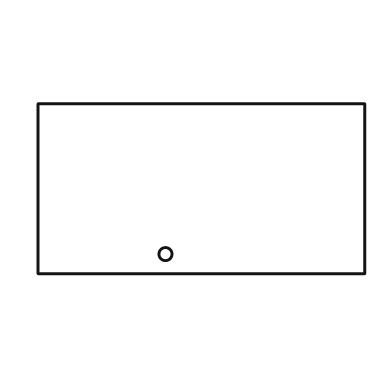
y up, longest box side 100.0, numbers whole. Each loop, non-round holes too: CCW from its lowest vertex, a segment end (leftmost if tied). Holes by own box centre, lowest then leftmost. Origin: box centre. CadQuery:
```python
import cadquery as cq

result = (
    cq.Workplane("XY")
    .moveTo(-50.0, -26.0)
    .lineTo(50.0, -26.0)
    .lineTo(50.0, 26.0)
    .lineTo(-50.0, 26.0)
    .close()
    .moveTo(-11.0, -20.0)
    .circle(2.0)
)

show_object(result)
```